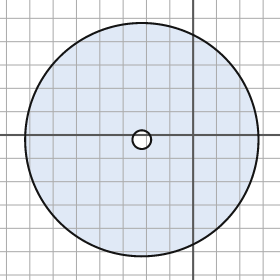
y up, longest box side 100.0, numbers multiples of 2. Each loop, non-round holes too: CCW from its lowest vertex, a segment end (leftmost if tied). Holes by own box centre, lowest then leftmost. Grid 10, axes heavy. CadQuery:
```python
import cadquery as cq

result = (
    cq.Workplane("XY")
    .moveTo(-22.0, -2.0)
    .circle(50.0)
    .moveTo(-22.0, -2.0)
    .circle(4.0)
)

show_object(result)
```